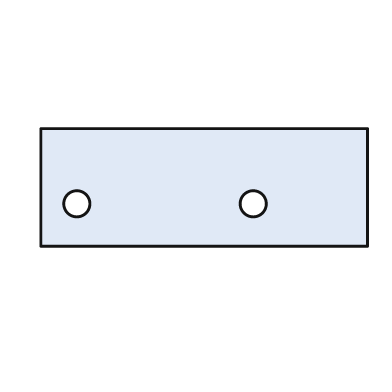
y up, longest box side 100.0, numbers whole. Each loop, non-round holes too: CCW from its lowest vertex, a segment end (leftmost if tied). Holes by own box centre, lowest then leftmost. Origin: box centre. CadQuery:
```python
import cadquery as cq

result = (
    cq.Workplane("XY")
    .moveTo(-50.0, -18.0)
    .lineTo(50.0, -18.0)
    .lineTo(50.0, 18.0)
    .lineTo(-50.0, 18.0)
    .close()
    .moveTo(-39.0, -5.0)
    .circle(4.0)
    .moveTo(15.0, -5.0)
    .circle(4.0)
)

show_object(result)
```